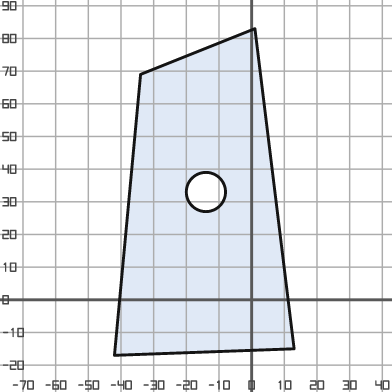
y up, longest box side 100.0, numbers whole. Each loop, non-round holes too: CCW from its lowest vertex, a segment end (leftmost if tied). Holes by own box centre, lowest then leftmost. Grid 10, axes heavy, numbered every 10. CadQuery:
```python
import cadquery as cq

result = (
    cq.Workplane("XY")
    .moveTo(-42.0, -17.0)
    .lineTo(13.0, -15.0)
    .lineTo(1.0, 83.0)
    .lineTo(-34.0, 69.0)
    .close()
    .moveTo(-14.0, 33.0)
    .circle(6.0)
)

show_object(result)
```